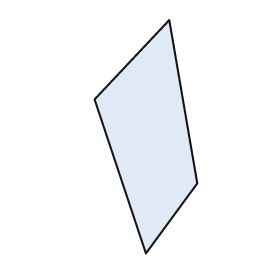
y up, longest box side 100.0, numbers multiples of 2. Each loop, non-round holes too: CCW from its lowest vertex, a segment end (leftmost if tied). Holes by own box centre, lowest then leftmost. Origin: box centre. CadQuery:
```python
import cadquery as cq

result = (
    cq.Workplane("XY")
    .moveTo(0.0, -50.0)
    .lineTo(22.0, -20.0)
    .lineTo(10.0, 50.0)
    .lineTo(-22.0, 16.0)
    .close()
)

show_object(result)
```